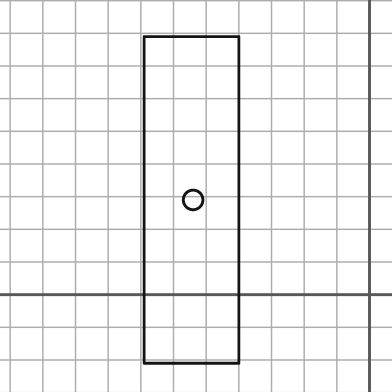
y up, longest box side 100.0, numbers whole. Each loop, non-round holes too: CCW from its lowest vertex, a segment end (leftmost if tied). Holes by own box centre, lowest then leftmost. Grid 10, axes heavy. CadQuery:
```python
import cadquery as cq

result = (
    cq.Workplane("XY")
    .moveTo(-69.0, -21.0)
    .lineTo(-40.0, -21.0)
    .lineTo(-40.0, 79.0)
    .lineTo(-69.0, 79.0)
    .close()
    .moveTo(-54.0, 29.0)
    .circle(3.0)
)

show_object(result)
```